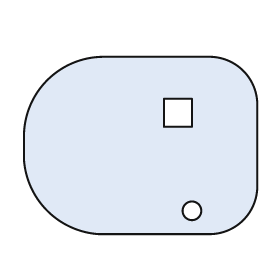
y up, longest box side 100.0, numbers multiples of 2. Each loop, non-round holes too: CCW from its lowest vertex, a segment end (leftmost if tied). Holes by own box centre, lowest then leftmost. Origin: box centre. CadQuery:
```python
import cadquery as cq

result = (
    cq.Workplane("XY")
    .moveTo(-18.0, -38.0)
    .lineTo(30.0, -38.0)
    .threePointArc((44.0, -32.0), (50.0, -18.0))
    .lineTo(50.0, 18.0)
    .threePointArc((44.0, 32.0), (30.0, 38.0))
    .lineTo(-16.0, 38.0)
    .threePointArc((-40.0, 28.0), (-50.0, 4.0))
    .lineTo(-50.0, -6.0)
    .threePointArc((-40.0, -28.0), (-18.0, -38.0))
    .close()
    .moveTo(22.0, -28.0)
    .circle(4.0)
    .moveTo(10.0, 8.0)
    .lineTo(22.0, 8.0)
    .lineTo(22.0, 20.0)
    .lineTo(10.0, 20.0)
    .close()
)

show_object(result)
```